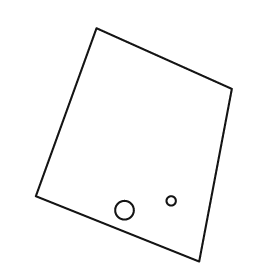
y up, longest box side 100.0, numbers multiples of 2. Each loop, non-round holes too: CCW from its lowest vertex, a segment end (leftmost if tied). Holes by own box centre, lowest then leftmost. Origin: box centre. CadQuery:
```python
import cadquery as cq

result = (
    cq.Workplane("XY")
    .moveTo(28.0, -50.0)
    .lineTo(42.0, 24.0)
    .lineTo(-16.0, 50.0)
    .lineTo(-42.0, -22.0)
    .close()
    .moveTo(-4.0, -28.0)
    .circle(4.0)
    .moveTo(16.0, -24.0)
    .circle(2.0)
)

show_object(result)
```